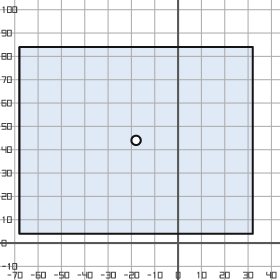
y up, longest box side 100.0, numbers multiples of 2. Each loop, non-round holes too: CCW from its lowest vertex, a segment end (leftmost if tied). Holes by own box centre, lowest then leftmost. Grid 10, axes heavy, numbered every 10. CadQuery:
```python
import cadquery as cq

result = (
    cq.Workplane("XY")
    .moveTo(-68.0, 4.0)
    .lineTo(32.0, 4.0)
    .lineTo(32.0, 84.0)
    .lineTo(-68.0, 84.0)
    .close()
    .moveTo(-18.0, 44.0)
    .circle(2.0)
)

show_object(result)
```